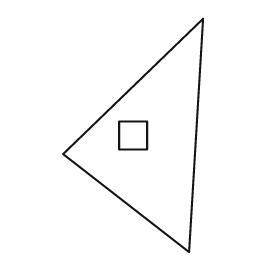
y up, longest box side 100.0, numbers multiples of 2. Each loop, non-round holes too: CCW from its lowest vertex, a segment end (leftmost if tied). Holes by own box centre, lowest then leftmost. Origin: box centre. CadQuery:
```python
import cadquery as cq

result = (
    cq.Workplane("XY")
    .moveTo(24.0, -50.0)
    .lineTo(30.0, 50.0)
    .lineTo(-30.0, -8.0)
    .close()
    .moveTo(-6.0, -6.0)
    .lineTo(6.0, -6.0)
    .lineTo(6.0, 6.0)
    .lineTo(-6.0, 6.0)
    .close()
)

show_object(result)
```